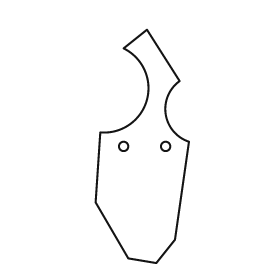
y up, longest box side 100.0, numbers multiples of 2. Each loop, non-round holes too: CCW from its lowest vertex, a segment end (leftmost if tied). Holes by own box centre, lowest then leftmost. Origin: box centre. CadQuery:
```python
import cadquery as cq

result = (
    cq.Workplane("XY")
    .moveTo(6.0, -50.0)
    .lineTo(14.0, -40.0)
    .lineTo(20.0, 2.0)
    .threePointArc((10.0, 14.0), (16.0, 28.0))
    .lineTo(2.0, 50.0)
    .lineTo(-8.0, 42.0)
    .threePointArc((2.0, 20.0), (-18.0, 6.0))
    .lineTo(-20.0, -24.0)
    .lineTo(-6.0, -48.0)
    .close()
    .moveTo(-8.0, 0.0)
    .circle(2.0)
    .moveTo(10.0, 0.0)
    .circle(2.0)
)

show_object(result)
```